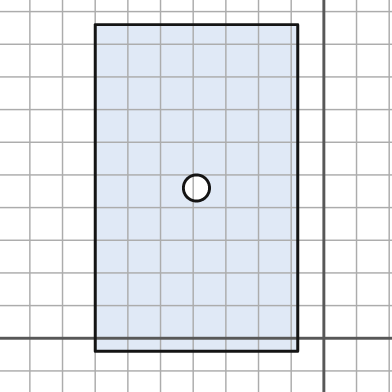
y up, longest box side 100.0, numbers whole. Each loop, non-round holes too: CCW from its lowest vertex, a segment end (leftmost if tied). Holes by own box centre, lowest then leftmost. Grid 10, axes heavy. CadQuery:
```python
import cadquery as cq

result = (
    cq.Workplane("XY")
    .moveTo(-70.0, -4.0)
    .lineTo(-8.0, -4.0)
    .lineTo(-8.0, 96.0)
    .lineTo(-70.0, 96.0)
    .close()
    .moveTo(-39.0, 46.0)
    .circle(4.0)
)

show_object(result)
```